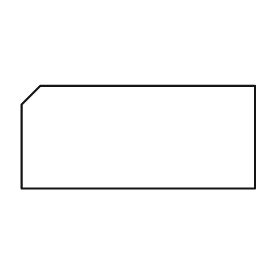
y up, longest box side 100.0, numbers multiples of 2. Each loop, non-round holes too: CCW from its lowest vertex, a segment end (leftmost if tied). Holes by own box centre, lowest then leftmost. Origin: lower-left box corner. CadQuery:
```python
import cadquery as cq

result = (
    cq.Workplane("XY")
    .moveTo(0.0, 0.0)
    .lineTo(100.0, 0.0)
    .lineTo(100.0, 44.0)
    .lineTo(8.0, 44.0)
    .lineTo(0.0, 36.0)
    .close()
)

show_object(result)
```